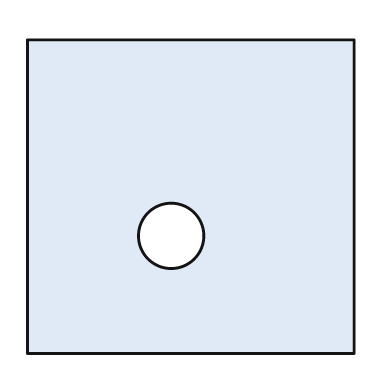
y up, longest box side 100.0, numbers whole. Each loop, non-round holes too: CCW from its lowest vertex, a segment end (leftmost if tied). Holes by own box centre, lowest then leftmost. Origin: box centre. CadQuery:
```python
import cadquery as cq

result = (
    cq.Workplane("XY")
    .moveTo(-50.0, -48.0)
    .lineTo(50.0, -48.0)
    .lineTo(50.0, 48.0)
    .lineTo(-50.0, 48.0)
    .close()
    .moveTo(-6.0, -12.0)
    .circle(10.0)
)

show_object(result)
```